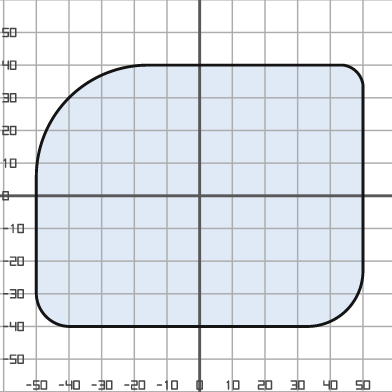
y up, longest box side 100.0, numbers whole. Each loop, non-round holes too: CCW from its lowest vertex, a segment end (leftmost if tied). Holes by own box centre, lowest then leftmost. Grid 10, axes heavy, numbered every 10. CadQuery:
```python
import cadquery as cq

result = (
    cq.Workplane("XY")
    .moveTo(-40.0, -40.0)
    .lineTo(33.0, -40.0)
    .threePointArc((45.0, -35.0), (50.0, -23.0))
    .lineTo(50.0, 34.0)
    .threePointArc((48.0, 38.0), (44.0, 40.0))
    .lineTo(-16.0, 40.0)
    .threePointArc((-40.0, 30.0), (-50.0, 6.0))
    .lineTo(-50.0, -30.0)
    .threePointArc((-47.0, -37.0), (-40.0, -40.0))
    .close()
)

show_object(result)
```